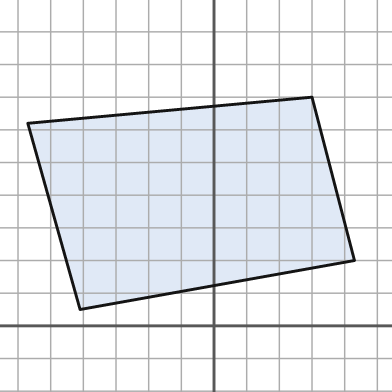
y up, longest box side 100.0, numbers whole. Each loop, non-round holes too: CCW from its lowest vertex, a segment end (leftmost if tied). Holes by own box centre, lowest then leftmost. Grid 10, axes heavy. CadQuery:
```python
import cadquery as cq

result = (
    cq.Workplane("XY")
    .moveTo(-41.0, 5.0)
    .lineTo(43.0, 20.0)
    .lineTo(30.0, 70.0)
    .lineTo(-57.0, 62.0)
    .close()
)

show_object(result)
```